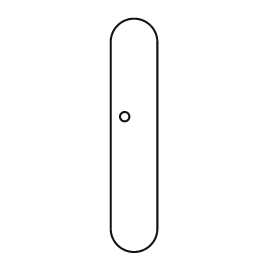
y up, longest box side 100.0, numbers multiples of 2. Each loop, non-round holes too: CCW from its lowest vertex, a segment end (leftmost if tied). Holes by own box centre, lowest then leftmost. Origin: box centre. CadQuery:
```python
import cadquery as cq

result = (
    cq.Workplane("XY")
    .moveTo(-10.0, -40.0)
    .threePointArc((0.0, -50.0), (10.0, -40.0))
    .lineTo(10.0, 40.0)
    .threePointArc((0.0, 50.0), (-10.0, 40.0))
    .close()
    .moveTo(-4.0, 8.0)
    .circle(2.0)
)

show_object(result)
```